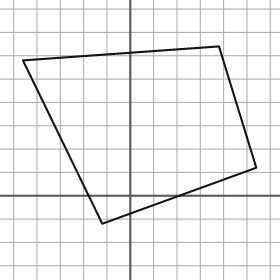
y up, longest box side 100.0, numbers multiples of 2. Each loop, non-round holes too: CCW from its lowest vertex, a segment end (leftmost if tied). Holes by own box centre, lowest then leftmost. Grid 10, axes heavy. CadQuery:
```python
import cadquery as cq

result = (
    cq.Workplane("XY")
    .moveTo(-12.0, -12.0)
    .lineTo(54.0, 12.0)
    .lineTo(38.0, 64.0)
    .lineTo(-46.0, 58.0)
    .close()
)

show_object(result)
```